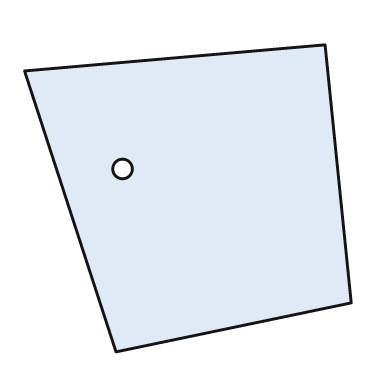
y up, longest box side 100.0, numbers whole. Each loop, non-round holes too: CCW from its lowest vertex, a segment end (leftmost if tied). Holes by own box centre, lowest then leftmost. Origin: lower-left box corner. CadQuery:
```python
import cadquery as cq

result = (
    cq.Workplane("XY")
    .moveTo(28.0, 0.0)
    .lineTo(100.0, 15.0)
    .lineTo(92.0, 94.0)
    .lineTo(0.0, 86.0)
    .close()
    .moveTo(30.0, 56.0)
    .circle(3.0)
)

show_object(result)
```